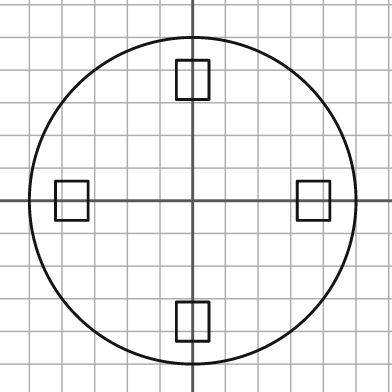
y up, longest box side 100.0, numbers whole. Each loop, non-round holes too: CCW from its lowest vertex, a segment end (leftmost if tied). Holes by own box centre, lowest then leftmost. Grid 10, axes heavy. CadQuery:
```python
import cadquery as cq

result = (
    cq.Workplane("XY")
    .moveTo(0.0, 0.0)
    .circle(50.0)
    .moveTo(-5.0, -43.0)
    .lineTo(5.0, -43.0)
    .lineTo(5.0, -31.0)
    .lineTo(-5.0, -31.0)
    .close()
    .moveTo(-42.0, -6.0)
    .lineTo(-32.0, -6.0)
    .lineTo(-32.0, 6.0)
    .lineTo(-42.0, 6.0)
    .close()
    .moveTo(32.0, -6.0)
    .lineTo(42.0, -6.0)
    .lineTo(42.0, 6.0)
    .lineTo(32.0, 6.0)
    .close()
    .moveTo(-5.0, 31.0)
    .lineTo(5.0, 31.0)
    .lineTo(5.0, 43.0)
    .lineTo(-5.0, 43.0)
    .close()
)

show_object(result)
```